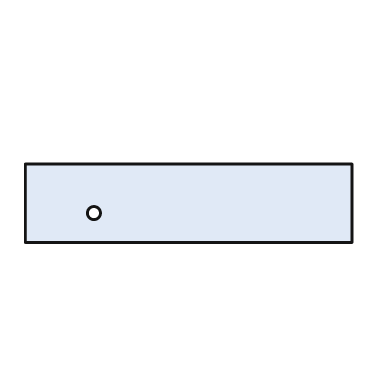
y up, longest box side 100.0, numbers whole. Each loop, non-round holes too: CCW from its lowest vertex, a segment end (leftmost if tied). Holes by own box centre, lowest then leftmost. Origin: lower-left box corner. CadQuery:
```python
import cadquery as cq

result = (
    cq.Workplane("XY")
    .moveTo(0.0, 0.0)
    .lineTo(100.0, 0.0)
    .lineTo(100.0, 24.0)
    .lineTo(0.0, 24.0)
    .close()
    .moveTo(21.0, 9.0)
    .circle(2.0)
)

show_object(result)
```